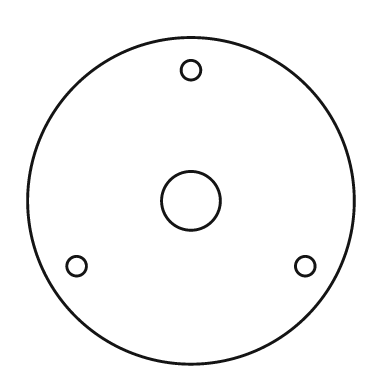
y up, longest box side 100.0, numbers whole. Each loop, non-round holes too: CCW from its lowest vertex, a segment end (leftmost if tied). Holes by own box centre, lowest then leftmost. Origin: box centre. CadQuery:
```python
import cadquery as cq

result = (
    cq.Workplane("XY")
    .moveTo(0.0, 0.0)
    .circle(50.0)
    .moveTo(-35.0, -20.0)
    .circle(3.0)
    .moveTo(35.0, -20.0)
    .circle(3.0)
    .moveTo(0.0, 0.0)
    .circle(9.0)
    .moveTo(0.0, 40.0)
    .circle(3.0)
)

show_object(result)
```